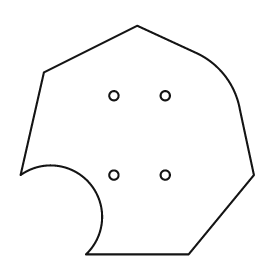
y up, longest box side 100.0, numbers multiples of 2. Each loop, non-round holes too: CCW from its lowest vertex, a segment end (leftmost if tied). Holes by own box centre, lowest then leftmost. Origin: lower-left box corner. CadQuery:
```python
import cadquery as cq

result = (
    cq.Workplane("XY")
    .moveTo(28.0, 0.0)
    .lineTo(72.0, 0.0)
    .lineTo(100.0, 34.0)
    .lineTo(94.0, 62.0)
    .threePointArc((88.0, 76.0), (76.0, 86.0))
    .lineTo(50.0, 98.0)
    .lineTo(10.0, 78.0)
    .lineTo(0.0, 34.0)
    .threePointArc((30.0, 30.0), (28.0, 0.0))
    .close()
    .moveTo(40.0, 34.0)
    .circle(2.0)
    .moveTo(62.0, 34.0)
    .circle(2.0)
    .moveTo(40.0, 68.0)
    .circle(2.0)
    .moveTo(62.0, 68.0)
    .circle(2.0)
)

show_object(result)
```